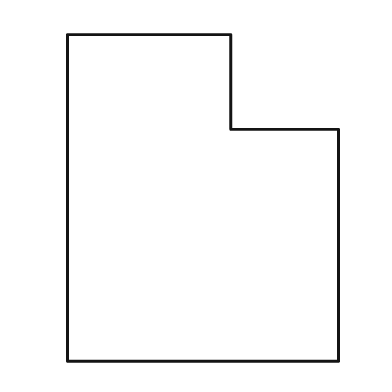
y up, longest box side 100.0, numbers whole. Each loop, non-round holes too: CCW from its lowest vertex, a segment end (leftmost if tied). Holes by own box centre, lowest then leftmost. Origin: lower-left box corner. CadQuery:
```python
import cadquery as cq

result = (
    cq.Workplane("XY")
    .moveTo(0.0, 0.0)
    .lineTo(83.0, 0.0)
    .lineTo(83.0, 71.0)
    .lineTo(50.0, 71.0)
    .lineTo(50.0, 100.0)
    .lineTo(0.0, 100.0)
    .close()
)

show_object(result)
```